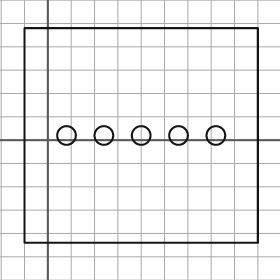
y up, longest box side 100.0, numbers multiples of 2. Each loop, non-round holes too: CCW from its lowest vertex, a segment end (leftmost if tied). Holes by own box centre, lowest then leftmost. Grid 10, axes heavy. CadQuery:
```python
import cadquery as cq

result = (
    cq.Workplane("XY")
    .moveTo(-10.0, -44.0)
    .lineTo(90.0, -44.0)
    .lineTo(90.0, 48.0)
    .lineTo(-10.0, 48.0)
    .close()
    .moveTo(8.0, 2.0)
    .circle(4.0)
    .moveTo(24.0, 2.0)
    .circle(4.0)
    .moveTo(40.0, 2.0)
    .circle(4.0)
    .moveTo(56.0, 2.0)
    .circle(4.0)
    .moveTo(72.0, 2.0)
    .circle(4.0)
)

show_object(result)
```